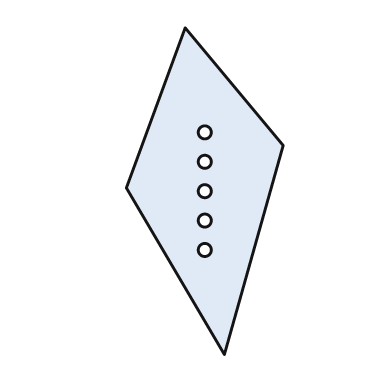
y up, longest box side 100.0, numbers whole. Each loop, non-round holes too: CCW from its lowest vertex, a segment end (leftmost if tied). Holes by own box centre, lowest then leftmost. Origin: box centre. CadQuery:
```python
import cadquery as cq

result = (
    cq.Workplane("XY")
    .moveTo(6.0, -50.0)
    .lineTo(24.0, 14.0)
    .lineTo(-6.0, 50.0)
    .lineTo(-24.0, 1.0)
    .close()
    .moveTo(0.0, -18.0)
    .circle(2.0)
    .moveTo(0.0, -9.0)
    .circle(2.0)
    .moveTo(0.0, 0.0)
    .circle(2.0)
    .moveTo(0.0, 9.0)
    .circle(2.0)
    .moveTo(0.0, 18.0)
    .circle(2.0)
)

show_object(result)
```